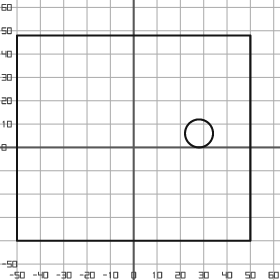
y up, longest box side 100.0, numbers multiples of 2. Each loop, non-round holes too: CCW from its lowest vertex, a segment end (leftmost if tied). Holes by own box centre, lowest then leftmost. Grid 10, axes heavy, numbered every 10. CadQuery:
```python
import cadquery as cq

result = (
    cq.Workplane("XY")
    .moveTo(-50.0, -40.0)
    .lineTo(50.0, -40.0)
    .lineTo(50.0, 48.0)
    .lineTo(-50.0, 48.0)
    .close()
    .moveTo(28.0, 6.0)
    .circle(6.0)
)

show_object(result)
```